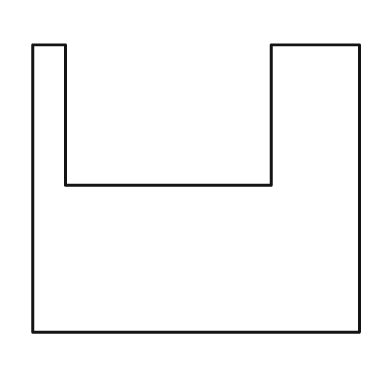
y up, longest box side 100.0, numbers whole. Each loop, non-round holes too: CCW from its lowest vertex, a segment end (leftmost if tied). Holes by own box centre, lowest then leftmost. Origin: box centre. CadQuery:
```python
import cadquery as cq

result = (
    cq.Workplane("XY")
    .moveTo(-50.0, -44.0)
    .lineTo(50.0, -44.0)
    .lineTo(50.0, 44.0)
    .lineTo(23.0, 44.0)
    .lineTo(23.0, 1.0)
    .lineTo(-40.0, 1.0)
    .lineTo(-40.0, 44.0)
    .lineTo(-50.0, 44.0)
    .close()
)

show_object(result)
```